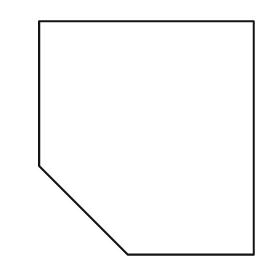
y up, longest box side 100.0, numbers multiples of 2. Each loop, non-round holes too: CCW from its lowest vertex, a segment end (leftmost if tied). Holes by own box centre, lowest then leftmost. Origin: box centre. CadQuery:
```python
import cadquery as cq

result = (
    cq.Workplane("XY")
    .moveTo(-8.0, -50.0)
    .lineTo(46.0, -50.0)
    .lineTo(46.0, 50.0)
    .lineTo(-46.0, 50.0)
    .lineTo(-46.0, -12.0)
    .close()
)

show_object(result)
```